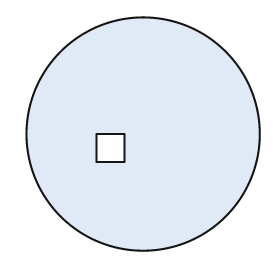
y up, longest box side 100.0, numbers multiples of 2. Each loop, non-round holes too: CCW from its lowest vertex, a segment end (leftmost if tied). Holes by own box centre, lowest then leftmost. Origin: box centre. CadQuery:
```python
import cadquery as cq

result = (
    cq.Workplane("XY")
    .moveTo(0.0, 0.0)
    .circle(50.0)
    .moveTo(-20.0, -12.0)
    .lineTo(-8.0, -12.0)
    .lineTo(-8.0, 0.0)
    .lineTo(-20.0, 0.0)
    .close()
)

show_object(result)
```